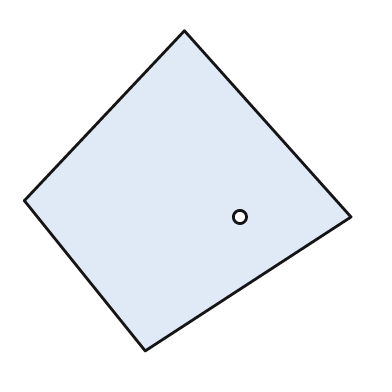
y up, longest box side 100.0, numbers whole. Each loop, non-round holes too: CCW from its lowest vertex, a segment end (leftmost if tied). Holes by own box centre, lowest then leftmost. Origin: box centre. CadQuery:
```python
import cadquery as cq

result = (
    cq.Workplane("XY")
    .moveTo(-13.0, -49.0)
    .lineTo(50.0, -8.0)
    .lineTo(-1.0, 49.0)
    .lineTo(-50.0, -3.0)
    .close()
    .moveTo(16.0, -8.0)
    .circle(2.0)
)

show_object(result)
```